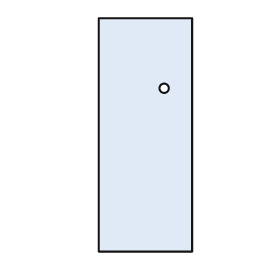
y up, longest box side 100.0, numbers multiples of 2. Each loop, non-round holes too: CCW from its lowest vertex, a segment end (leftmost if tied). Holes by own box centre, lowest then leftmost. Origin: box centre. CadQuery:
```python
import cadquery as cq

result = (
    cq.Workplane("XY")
    .moveTo(-20.0, -50.0)
    .lineTo(20.0, -50.0)
    .lineTo(20.0, 50.0)
    .lineTo(-20.0, 50.0)
    .close()
    .moveTo(8.0, 20.0)
    .circle(2.0)
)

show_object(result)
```